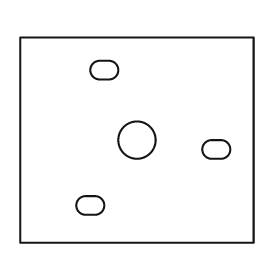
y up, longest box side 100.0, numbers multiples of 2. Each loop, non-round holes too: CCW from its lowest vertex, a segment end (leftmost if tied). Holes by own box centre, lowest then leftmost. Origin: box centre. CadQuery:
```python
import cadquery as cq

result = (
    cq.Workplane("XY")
    .moveTo(-50.0, -44.0)
    .lineTo(50.0, -44.0)
    .lineTo(50.0, 44.0)
    .lineTo(-50.0, 44.0)
    .close()
    .moveTo(-22.0, -32.0)
    .lineTo(-18.0, -32.0)
    .threePointArc((-14.0, -28.0), (-18.0, -24.0))
    .lineTo(-22.0, -24.0)
    .threePointArc((-26.0, -28.0), (-22.0, -32.0))
    .close()
    .moveTo(32.0, -8.0)
    .lineTo(36.0, -8.0)
    .threePointArc((40.0, -4.0), (36.0, 0.0))
    .lineTo(32.0, 0.0)
    .threePointArc((28.0, -4.0), (32.0, -8.0))
    .close()
    .moveTo(0.0, 0.0)
    .circle(8.0)
    .moveTo(-16.0, 26.0)
    .lineTo(-12.0, 26.0)
    .threePointArc((-8.0, 30.0), (-12.0, 34.0))
    .lineTo(-16.0, 34.0)
    .threePointArc((-20.0, 30.0), (-16.0, 26.0))
    .close()
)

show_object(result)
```